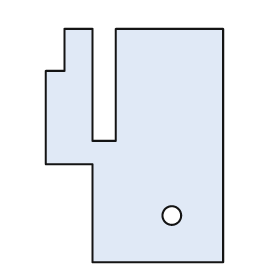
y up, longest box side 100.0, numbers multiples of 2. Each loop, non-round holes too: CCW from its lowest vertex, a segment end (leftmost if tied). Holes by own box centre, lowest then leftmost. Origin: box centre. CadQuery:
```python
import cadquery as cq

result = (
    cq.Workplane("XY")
    .moveTo(-18.0, -50.0)
    .lineTo(38.0, -50.0)
    .lineTo(38.0, 50.0)
    .lineTo(-8.0, 50.0)
    .lineTo(-8.0, 2.0)
    .lineTo(-18.0, 2.0)
    .lineTo(-18.0, 50.0)
    .lineTo(-30.0, 50.0)
    .lineTo(-30.0, 32.0)
    .lineTo(-38.0, 32.0)
    .lineTo(-38.0, -8.0)
    .lineTo(-18.0, -8.0)
    .close()
    .moveTo(16.0, -30.0)
    .circle(4.0)
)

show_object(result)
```